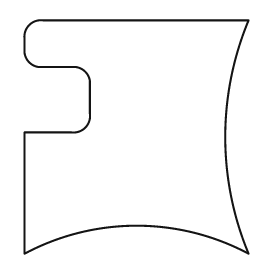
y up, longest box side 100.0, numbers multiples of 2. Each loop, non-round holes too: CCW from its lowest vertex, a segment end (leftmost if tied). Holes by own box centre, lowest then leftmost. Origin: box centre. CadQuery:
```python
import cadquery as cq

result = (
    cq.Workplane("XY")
    .moveTo(-48.0, -50.0)
    .threePointArc((0.0, -38.0), (48.0, -50.0))
    .threePointArc((38.0, 0.0), (48.0, 50.0))
    .lineTo(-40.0, 50.0)
    .threePointArc((-46.0, 48.0), (-48.0, 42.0))
    .lineTo(-48.0, 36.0)
    .threePointArc((-46.0, 32.0), (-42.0, 30.0))
    .lineTo(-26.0, 30.0)
    .threePointArc((-22.0, 28.0), (-20.0, 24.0))
    .lineTo(-20.0, 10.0)
    .threePointArc((-22.0, 4.0), (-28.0, 2.0))
    .lineTo(-48.0, 2.0)
    .close()
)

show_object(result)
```